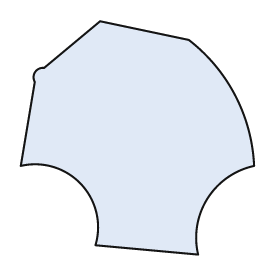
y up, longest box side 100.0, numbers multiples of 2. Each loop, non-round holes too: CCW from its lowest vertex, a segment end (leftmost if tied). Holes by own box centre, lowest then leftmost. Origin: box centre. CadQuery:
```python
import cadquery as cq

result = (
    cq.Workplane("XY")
    .moveTo(26.0, -50.0)
    .threePointArc((30.0, -26.0), (50.0, -12.0))
    .threePointArc((42.0, 18.0), (22.0, 42.0))
    .lineTo(-16.0, 50.0)
    .lineTo(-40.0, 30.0)
    .threePointArc((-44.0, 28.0), (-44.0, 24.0))
    .lineTo(-50.0, -12.0)
    .threePointArc((-24.0, -20.0), (-18.0, -46.0))
    .close()
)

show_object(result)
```